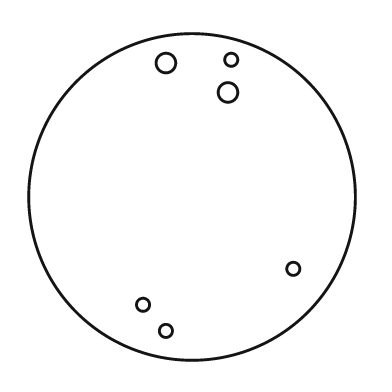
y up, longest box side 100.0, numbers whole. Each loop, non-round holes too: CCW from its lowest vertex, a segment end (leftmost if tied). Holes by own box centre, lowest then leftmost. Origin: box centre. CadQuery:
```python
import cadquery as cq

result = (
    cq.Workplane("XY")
    .moveTo(0.0, 0.0)
    .circle(50.0)
    .moveTo(-8.0, -41.0)
    .circle(2.0)
    .moveTo(-15.0, -33.0)
    .circle(2.0)
    .moveTo(31.0, -22.0)
    .circle(2.0)
    .moveTo(11.0, 32.0)
    .circle(3.0)
    .moveTo(-8.0, 41.0)
    .circle(3.0)
    .moveTo(12.0, 42.0)
    .circle(2.0)
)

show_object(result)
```